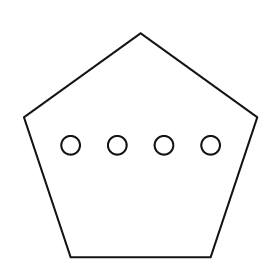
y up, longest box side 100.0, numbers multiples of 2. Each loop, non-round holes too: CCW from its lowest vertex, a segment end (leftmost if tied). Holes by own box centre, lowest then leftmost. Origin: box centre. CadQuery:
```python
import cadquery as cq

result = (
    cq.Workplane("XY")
    .moveTo(-30.0, -48.0)
    .lineTo(30.0, -48.0)
    .lineTo(50.0, 12.0)
    .lineTo(0.0, 48.0)
    .lineTo(-50.0, 12.0)
    .close()
    .moveTo(-30.0, 0.0)
    .circle(4.0)
    .moveTo(-10.0, 0.0)
    .circle(4.0)
    .moveTo(10.0, 0.0)
    .circle(4.0)
    .moveTo(30.0, 0.0)
    .circle(4.0)
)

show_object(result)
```